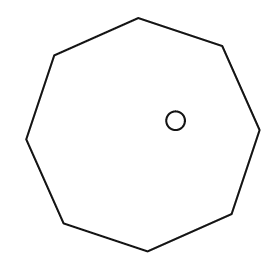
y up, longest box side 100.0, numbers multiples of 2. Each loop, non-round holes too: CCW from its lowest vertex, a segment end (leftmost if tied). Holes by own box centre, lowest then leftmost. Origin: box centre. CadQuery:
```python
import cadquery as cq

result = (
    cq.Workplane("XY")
    .moveTo(2.0, -50.0)
    .lineTo(38.0, -34.0)
    .lineTo(50.0, 2.0)
    .lineTo(34.0, 38.0)
    .lineTo(-2.0, 50.0)
    .lineTo(-38.0, 34.0)
    .lineTo(-50.0, -2.0)
    .lineTo(-34.0, -38.0)
    .close()
    .moveTo(14.0, 6.0)
    .circle(4.0)
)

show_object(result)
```